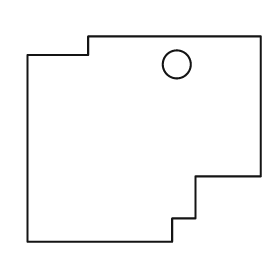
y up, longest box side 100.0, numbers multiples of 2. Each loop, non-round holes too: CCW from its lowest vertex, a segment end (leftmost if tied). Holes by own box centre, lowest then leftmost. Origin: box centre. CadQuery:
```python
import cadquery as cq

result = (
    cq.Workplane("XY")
    .moveTo(-50.0, -44.0)
    .lineTo(12.0, -44.0)
    .lineTo(12.0, -34.0)
    .lineTo(22.0, -34.0)
    .lineTo(22.0, -16.0)
    .lineTo(50.0, -16.0)
    .lineTo(50.0, 44.0)
    .lineTo(-24.0, 44.0)
    .lineTo(-24.0, 36.0)
    .lineTo(-50.0, 36.0)
    .close()
    .moveTo(14.0, 32.0)
    .circle(6.0)
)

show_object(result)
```